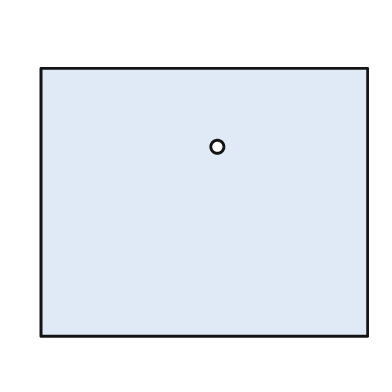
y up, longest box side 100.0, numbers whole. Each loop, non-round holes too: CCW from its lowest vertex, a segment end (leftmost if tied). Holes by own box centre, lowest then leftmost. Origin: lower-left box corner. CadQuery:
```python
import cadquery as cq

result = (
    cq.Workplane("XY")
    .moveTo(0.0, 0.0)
    .lineTo(100.0, 0.0)
    .lineTo(100.0, 82.0)
    .lineTo(0.0, 82.0)
    .close()
    .moveTo(54.0, 58.0)
    .circle(2.0)
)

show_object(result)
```